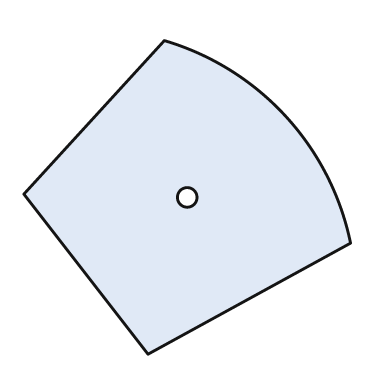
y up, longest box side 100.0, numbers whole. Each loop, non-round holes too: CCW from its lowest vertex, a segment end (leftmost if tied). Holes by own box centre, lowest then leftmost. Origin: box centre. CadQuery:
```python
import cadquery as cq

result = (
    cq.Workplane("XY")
    .moveTo(-12.0, -48.0)
    .lineTo(50.0, -14.0)
    .threePointArc((30.0, 25.0), (-7.0, 48.0))
    .lineTo(-50.0, 1.0)
    .close()
    .moveTo(0.0, 0.0)
    .circle(3.0)
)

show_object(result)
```